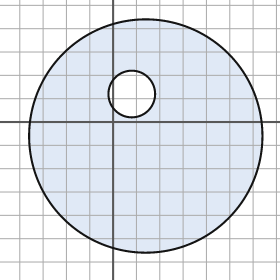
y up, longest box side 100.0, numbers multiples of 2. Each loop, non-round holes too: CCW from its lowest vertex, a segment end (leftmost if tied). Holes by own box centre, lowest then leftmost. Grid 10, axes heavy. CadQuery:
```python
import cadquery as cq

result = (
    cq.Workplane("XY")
    .moveTo(14.0, -6.0)
    .circle(50.0)
    .moveTo(8.0, 12.0)
    .circle(10.0)
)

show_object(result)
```